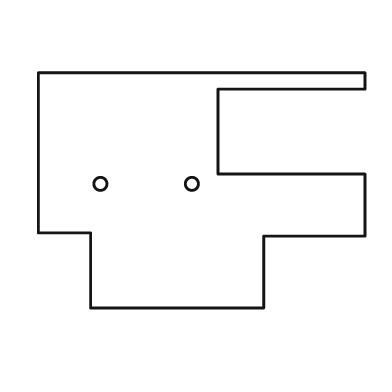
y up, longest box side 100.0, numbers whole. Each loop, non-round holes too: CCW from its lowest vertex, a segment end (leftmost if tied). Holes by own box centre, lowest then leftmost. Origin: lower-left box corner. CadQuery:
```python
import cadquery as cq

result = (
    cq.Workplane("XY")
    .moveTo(16.0, 0.0)
    .lineTo(69.0, 0.0)
    .lineTo(69.0, 22.0)
    .lineTo(100.0, 22.0)
    .lineTo(100.0, 41.0)
    .lineTo(55.0, 41.0)
    .lineTo(55.0, 67.0)
    .lineTo(100.0, 67.0)
    .lineTo(100.0, 72.0)
    .lineTo(0.0, 72.0)
    .lineTo(0.0, 23.0)
    .lineTo(16.0, 23.0)
    .close()
    .moveTo(19.0, 38.0)
    .circle(2.0)
    .moveTo(47.0, 38.0)
    .circle(2.0)
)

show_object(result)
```